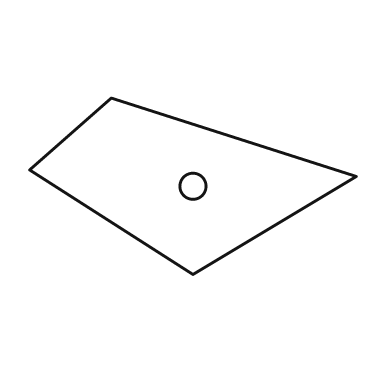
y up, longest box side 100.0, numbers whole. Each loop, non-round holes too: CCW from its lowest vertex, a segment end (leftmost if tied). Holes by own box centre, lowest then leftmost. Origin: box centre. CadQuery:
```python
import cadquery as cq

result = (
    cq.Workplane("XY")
    .moveTo(0.0, -27.0)
    .lineTo(50.0, 3.0)
    .lineTo(-25.0, 27.0)
    .lineTo(-50.0, 5.0)
    .close()
    .moveTo(0.0, 0.0)
    .circle(4.0)
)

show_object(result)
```